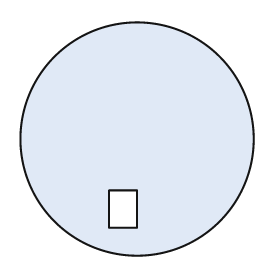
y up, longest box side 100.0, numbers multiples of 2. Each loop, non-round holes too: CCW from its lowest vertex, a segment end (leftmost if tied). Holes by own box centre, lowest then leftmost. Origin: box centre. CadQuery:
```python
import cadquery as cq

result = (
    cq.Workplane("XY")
    .moveTo(0.0, 0.0)
    .circle(50.0)
    .moveTo(-12.0, -38.0)
    .lineTo(0.0, -38.0)
    .lineTo(0.0, -22.0)
    .lineTo(-12.0, -22.0)
    .close()
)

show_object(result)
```